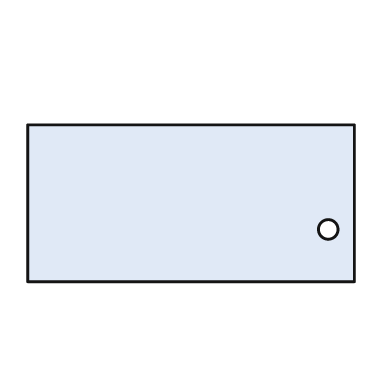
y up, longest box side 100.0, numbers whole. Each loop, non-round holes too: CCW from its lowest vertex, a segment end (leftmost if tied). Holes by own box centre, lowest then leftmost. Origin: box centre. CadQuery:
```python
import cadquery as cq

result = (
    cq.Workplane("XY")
    .moveTo(-50.0, -24.0)
    .lineTo(50.0, -24.0)
    .lineTo(50.0, 24.0)
    .lineTo(-50.0, 24.0)
    .close()
    .moveTo(42.0, -8.0)
    .circle(3.0)
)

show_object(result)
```